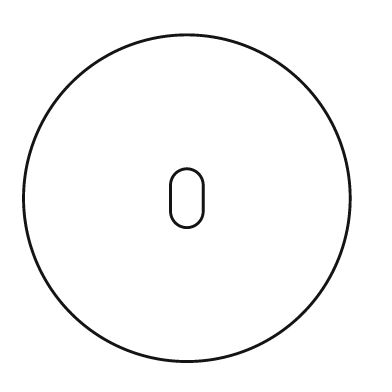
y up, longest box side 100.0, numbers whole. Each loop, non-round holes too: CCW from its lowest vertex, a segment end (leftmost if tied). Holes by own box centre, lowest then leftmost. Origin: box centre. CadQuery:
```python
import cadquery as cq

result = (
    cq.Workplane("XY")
    .moveTo(0.0, 0.0)
    .circle(50.0)
    .moveTo(-5.0, -4.0)
    .threePointArc((0.0, -9.0), (5.0, -4.0))
    .lineTo(5.0, 4.0)
    .threePointArc((0.0, 9.0), (-5.0, 4.0))
    .close()
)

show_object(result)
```